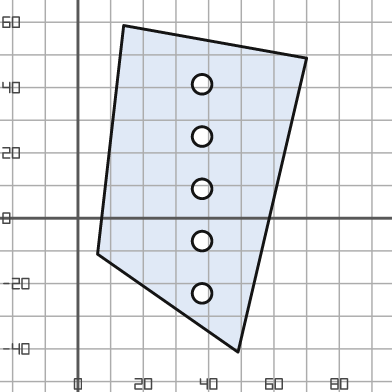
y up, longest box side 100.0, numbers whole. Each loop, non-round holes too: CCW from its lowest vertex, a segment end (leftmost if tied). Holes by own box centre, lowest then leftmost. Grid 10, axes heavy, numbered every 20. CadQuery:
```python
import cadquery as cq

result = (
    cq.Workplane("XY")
    .moveTo(49.0, -41.0)
    .lineTo(70.0, 49.0)
    .lineTo(14.0, 59.0)
    .lineTo(6.0, -11.0)
    .close()
    .moveTo(38.0, -23.0)
    .circle(3.0)
    .moveTo(38.0, -7.0)
    .circle(3.0)
    .moveTo(38.0, 9.0)
    .circle(3.0)
    .moveTo(38.0, 25.0)
    .circle(3.0)
    .moveTo(38.0, 41.0)
    .circle(3.0)
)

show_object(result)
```